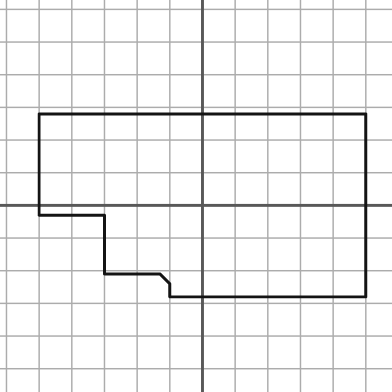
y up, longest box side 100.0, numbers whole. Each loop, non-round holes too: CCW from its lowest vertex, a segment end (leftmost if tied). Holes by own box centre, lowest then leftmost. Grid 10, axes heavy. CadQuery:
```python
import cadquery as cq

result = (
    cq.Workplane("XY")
    .moveTo(-10.0, -28.0)
    .lineTo(50.0, -28.0)
    .lineTo(50.0, 28.0)
    .lineTo(-50.0, 28.0)
    .lineTo(-50.0, -3.0)
    .lineTo(-30.0, -3.0)
    .lineTo(-30.0, -21.0)
    .lineTo(-13.0, -21.0)
    .lineTo(-10.0, -24.0)
    .close()
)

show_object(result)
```